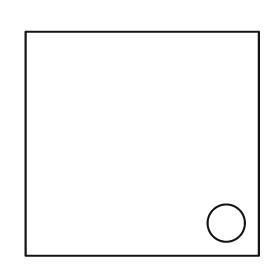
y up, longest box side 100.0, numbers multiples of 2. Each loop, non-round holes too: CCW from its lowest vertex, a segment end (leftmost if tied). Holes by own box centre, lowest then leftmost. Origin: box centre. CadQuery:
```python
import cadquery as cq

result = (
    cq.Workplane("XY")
    .moveTo(-50.0, -48.0)
    .lineTo(50.0, -48.0)
    .lineTo(50.0, 48.0)
    .lineTo(-50.0, 48.0)
    .close()
    .moveTo(36.0, -34.0)
    .circle(8.0)
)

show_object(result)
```